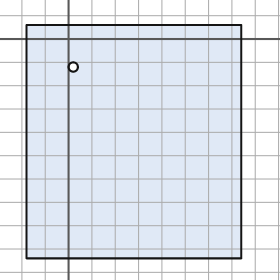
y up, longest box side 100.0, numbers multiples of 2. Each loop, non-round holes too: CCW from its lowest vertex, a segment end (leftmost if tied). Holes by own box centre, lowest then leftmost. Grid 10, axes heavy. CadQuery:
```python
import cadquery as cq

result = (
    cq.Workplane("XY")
    .moveTo(-18.0, -94.0)
    .lineTo(74.0, -94.0)
    .lineTo(74.0, 6.0)
    .lineTo(-18.0, 6.0)
    .close()
    .moveTo(2.0, -12.0)
    .circle(2.0)
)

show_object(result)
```